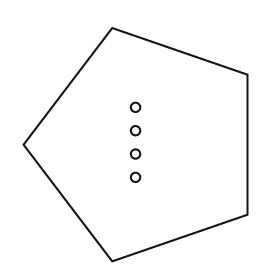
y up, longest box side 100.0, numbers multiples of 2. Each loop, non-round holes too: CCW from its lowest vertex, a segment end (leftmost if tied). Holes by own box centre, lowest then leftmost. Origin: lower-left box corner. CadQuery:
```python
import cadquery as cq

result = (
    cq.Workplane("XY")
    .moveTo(38.0, 0.0)
    .lineTo(96.0, 20.0)
    .lineTo(96.0, 80.0)
    .lineTo(38.0, 100.0)
    .lineTo(0.0, 50.0)
    .close()
    .moveTo(48.0, 36.0)
    .circle(2.0)
    .moveTo(48.0, 46.0)
    .circle(2.0)
    .moveTo(48.0, 56.0)
    .circle(2.0)
    .moveTo(48.0, 66.0)
    .circle(2.0)
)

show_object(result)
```